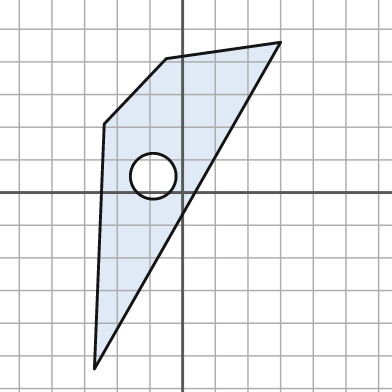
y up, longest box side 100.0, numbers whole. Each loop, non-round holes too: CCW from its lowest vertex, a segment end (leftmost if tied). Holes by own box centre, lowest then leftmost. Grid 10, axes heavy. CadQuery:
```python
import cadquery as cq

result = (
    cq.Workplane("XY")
    .moveTo(-27.0, -54.0)
    .lineTo(30.0, 46.0)
    .lineTo(-5.0, 41.0)
    .lineTo(-24.0, 21.0)
    .close()
    .moveTo(-9.0, 5.0)
    .circle(7.0)
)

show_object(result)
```